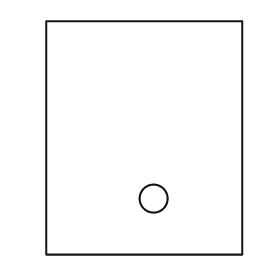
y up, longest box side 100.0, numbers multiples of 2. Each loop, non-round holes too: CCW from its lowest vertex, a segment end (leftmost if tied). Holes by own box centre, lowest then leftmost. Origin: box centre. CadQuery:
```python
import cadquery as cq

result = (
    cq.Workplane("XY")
    .moveTo(-42.0, -50.0)
    .lineTo(42.0, -50.0)
    .lineTo(42.0, 50.0)
    .lineTo(-42.0, 50.0)
    .close()
    .moveTo(4.0, -26.0)
    .circle(6.0)
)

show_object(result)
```